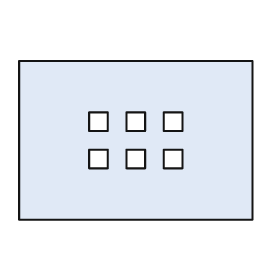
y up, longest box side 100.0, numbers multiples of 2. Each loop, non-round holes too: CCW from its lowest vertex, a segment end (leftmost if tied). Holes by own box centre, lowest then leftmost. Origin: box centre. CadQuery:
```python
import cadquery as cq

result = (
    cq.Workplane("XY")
    .moveTo(-50.0, -34.0)
    .lineTo(50.0, -34.0)
    .lineTo(50.0, 34.0)
    .lineTo(-50.0, 34.0)
    .close()
    .moveTo(-20.0, -12.0)
    .lineTo(-12.0, -12.0)
    .lineTo(-12.0, -4.0)
    .lineTo(-20.0, -4.0)
    .close()
    .moveTo(-4.0, -12.0)
    .lineTo(4.0, -12.0)
    .lineTo(4.0, -4.0)
    .lineTo(-4.0, -4.0)
    .close()
    .moveTo(12.0, -12.0)
    .lineTo(20.0, -12.0)
    .lineTo(20.0, -4.0)
    .lineTo(12.0, -4.0)
    .close()
    .moveTo(-20.0, 4.0)
    .lineTo(-12.0, 4.0)
    .lineTo(-12.0, 12.0)
    .lineTo(-20.0, 12.0)
    .close()
    .moveTo(-4.0, 4.0)
    .lineTo(4.0, 4.0)
    .lineTo(4.0, 12.0)
    .lineTo(-4.0, 12.0)
    .close()
    .moveTo(12.0, 4.0)
    .lineTo(20.0, 4.0)
    .lineTo(20.0, 12.0)
    .lineTo(12.0, 12.0)
    .close()
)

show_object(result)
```